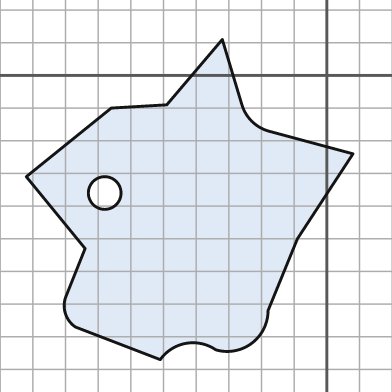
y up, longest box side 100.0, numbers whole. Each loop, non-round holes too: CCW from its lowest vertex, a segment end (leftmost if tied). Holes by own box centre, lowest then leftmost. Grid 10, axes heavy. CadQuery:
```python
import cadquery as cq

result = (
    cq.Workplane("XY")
    .moveTo(-51.0, -87.0)
    .threePointArc((-43.0, -82.0), (-34.0, -84.0))
    .threePointArc((-23.0, -82.0), (-18.0, -72.0))
    .lineTo(-9.0, -50.0)
    .lineTo(8.0, -24.0)
    .lineTo(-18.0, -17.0)
    .threePointArc((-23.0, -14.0), (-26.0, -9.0))
    .lineTo(-32.0, 11.0)
    .lineTo(-49.0, -9.0)
    .lineTo(-66.0, -10.0)
    .lineTo(-92.0, -31.0)
    .lineTo(-74.0, -53.0)
    .lineTo(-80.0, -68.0)
    .threePointArc((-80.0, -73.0), (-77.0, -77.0))
    .close()
    .moveTo(-68.0, -36.0)
    .circle(5.0)
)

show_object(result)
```